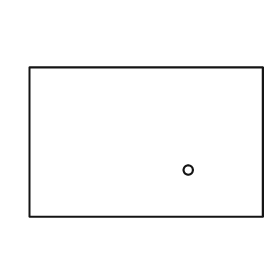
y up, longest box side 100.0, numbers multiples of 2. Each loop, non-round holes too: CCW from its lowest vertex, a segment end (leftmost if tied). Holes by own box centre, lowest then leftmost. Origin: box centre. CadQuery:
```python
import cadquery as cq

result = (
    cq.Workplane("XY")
    .moveTo(-50.0, -32.0)
    .lineTo(50.0, -32.0)
    .lineTo(50.0, 32.0)
    .lineTo(-50.0, 32.0)
    .close()
    .moveTo(18.0, -12.0)
    .circle(2.0)
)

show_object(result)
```